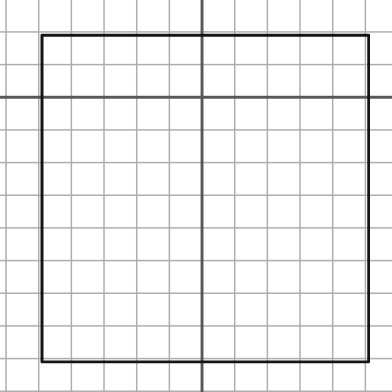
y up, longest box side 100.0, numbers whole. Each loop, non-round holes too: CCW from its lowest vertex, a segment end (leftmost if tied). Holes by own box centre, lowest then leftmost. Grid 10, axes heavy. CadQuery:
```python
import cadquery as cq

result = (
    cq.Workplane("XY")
    .moveTo(-49.0, -81.0)
    .lineTo(51.0, -81.0)
    .lineTo(51.0, 19.0)
    .lineTo(-49.0, 19.0)
    .close()
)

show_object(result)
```